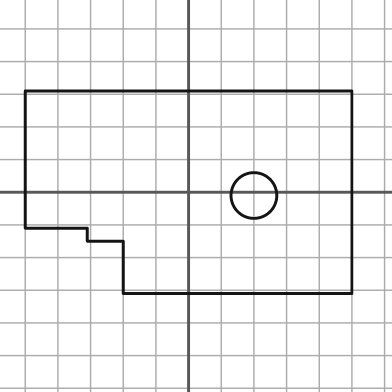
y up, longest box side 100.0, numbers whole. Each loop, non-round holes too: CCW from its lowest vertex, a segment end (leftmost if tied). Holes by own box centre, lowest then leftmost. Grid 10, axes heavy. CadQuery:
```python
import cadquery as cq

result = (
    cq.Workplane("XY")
    .moveTo(-20.0, -31.0)
    .lineTo(50.0, -31.0)
    .lineTo(50.0, 31.0)
    .lineTo(-50.0, 31.0)
    .lineTo(-50.0, -11.0)
    .lineTo(-31.0, -11.0)
    .lineTo(-31.0, -15.0)
    .lineTo(-20.0, -15.0)
    .close()
    .moveTo(20.0, -1.0)
    .circle(7.0)
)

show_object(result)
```